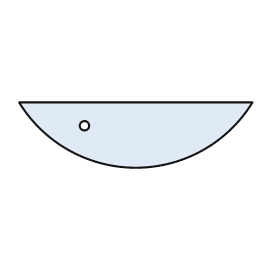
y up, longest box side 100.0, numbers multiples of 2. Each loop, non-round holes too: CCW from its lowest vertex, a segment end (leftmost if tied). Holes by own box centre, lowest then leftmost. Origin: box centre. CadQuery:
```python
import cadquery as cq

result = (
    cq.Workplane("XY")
    .moveTo(-50.0, 14.0)
    .threePointArc((0.0, -14.0), (50.0, 14.0))
    .close()
    .moveTo(-22.0, 4.0)
    .circle(2.0)
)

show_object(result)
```